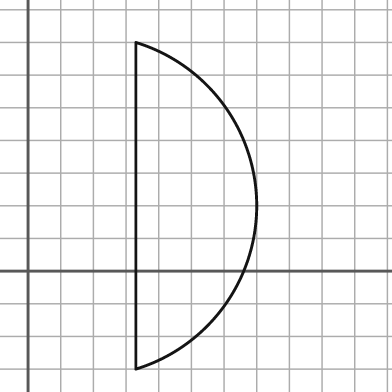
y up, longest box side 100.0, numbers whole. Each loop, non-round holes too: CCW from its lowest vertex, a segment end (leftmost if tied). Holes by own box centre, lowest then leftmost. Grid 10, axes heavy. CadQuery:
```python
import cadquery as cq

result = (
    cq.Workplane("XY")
    .moveTo(33.0, -30.0)
    .threePointArc((70.0, 20.0), (33.0, 70.0))
    .close()
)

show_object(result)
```